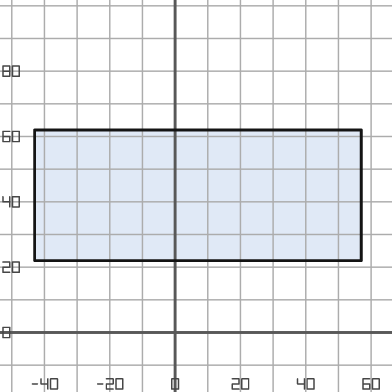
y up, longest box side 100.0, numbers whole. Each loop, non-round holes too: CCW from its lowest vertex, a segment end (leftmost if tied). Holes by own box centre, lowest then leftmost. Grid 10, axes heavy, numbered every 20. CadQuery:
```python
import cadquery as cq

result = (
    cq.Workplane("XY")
    .moveTo(-43.0, 22.0)
    .lineTo(57.0, 22.0)
    .lineTo(57.0, 62.0)
    .lineTo(-43.0, 62.0)
    .close()
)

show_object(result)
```